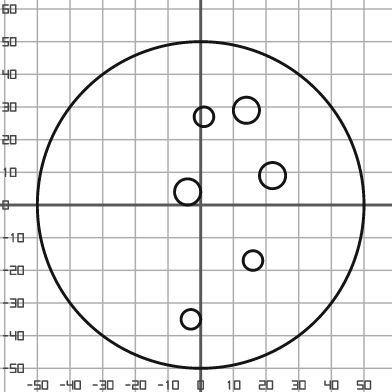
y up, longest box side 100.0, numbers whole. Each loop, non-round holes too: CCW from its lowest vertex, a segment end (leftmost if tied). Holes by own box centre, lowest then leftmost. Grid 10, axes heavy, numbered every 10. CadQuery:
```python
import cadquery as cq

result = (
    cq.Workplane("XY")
    .moveTo(0.0, 0.0)
    .circle(50.0)
    .moveTo(-3.0, -35.0)
    .circle(3.0)
    .moveTo(16.0, -17.0)
    .circle(3.0)
    .moveTo(-4.0, 4.0)
    .circle(4.0)
    .moveTo(22.0, 9.0)
    .circle(4.0)
    .moveTo(1.0, 27.0)
    .circle(3.0)
    .moveTo(14.0, 29.0)
    .circle(4.0)
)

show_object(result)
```